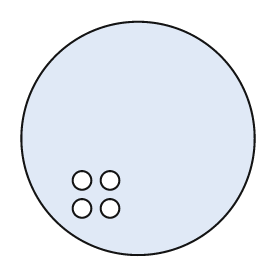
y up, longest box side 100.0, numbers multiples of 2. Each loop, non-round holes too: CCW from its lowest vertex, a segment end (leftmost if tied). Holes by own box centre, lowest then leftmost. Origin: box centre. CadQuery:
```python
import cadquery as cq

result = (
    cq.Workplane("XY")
    .moveTo(0.0, 0.0)
    .circle(50.0)
    .moveTo(-24.0, -30.0)
    .circle(4.0)
    .moveTo(-12.0, -30.0)
    .circle(4.0)
    .moveTo(-24.0, -18.0)
    .circle(4.0)
    .moveTo(-12.0, -18.0)
    .circle(4.0)
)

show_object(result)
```